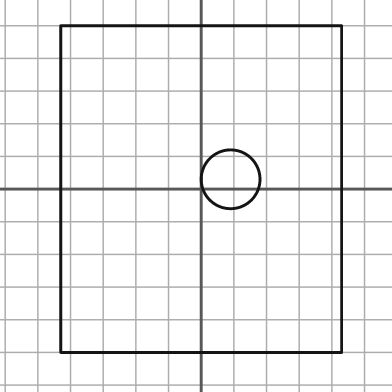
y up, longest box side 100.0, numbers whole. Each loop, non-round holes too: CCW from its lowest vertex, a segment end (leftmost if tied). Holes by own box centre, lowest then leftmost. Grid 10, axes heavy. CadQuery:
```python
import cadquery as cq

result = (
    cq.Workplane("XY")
    .moveTo(-43.0, -50.0)
    .lineTo(43.0, -50.0)
    .lineTo(43.0, 50.0)
    .lineTo(-43.0, 50.0)
    .close()
    .moveTo(9.0, 3.0)
    .circle(9.0)
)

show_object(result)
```